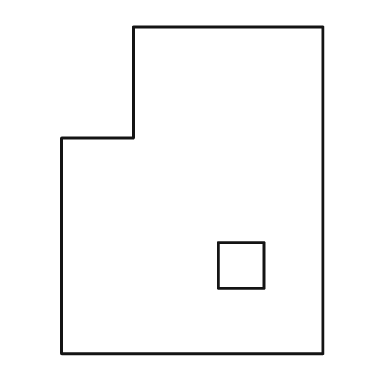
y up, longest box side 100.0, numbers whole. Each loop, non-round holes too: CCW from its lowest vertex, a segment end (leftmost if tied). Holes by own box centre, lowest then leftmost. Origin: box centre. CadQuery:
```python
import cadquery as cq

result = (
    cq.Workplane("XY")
    .moveTo(-40.0, -50.0)
    .lineTo(40.0, -50.0)
    .lineTo(40.0, 50.0)
    .lineTo(-18.0, 50.0)
    .lineTo(-18.0, 16.0)
    .lineTo(-40.0, 16.0)
    .close()
    .moveTo(8.0, -30.0)
    .lineTo(22.0, -30.0)
    .lineTo(22.0, -16.0)
    .lineTo(8.0, -16.0)
    .close()
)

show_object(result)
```